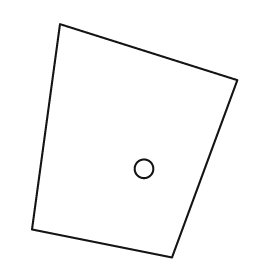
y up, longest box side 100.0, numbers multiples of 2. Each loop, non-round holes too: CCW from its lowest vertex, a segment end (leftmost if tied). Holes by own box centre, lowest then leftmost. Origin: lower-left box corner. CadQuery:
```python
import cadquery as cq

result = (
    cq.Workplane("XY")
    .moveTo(60.0, 0.0)
    .lineTo(88.0, 76.0)
    .lineTo(12.0, 100.0)
    .lineTo(0.0, 12.0)
    .close()
    .moveTo(48.0, 38.0)
    .circle(4.0)
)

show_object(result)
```